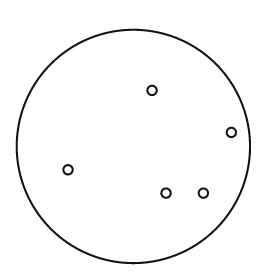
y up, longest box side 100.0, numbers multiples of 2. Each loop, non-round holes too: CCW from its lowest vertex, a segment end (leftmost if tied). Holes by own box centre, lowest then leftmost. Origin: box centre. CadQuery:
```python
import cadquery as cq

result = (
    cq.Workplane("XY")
    .moveTo(0.0, 0.0)
    .circle(50.0)
    .moveTo(14.0, -20.0)
    .circle(2.0)
    .moveTo(30.0, -20.0)
    .circle(2.0)
    .moveTo(-28.0, -10.0)
    .circle(2.0)
    .moveTo(42.0, 6.0)
    .circle(2.0)
    .moveTo(8.0, 24.0)
    .circle(2.0)
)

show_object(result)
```